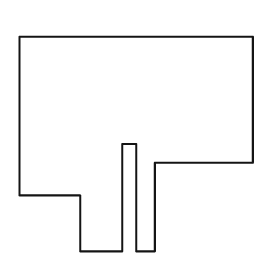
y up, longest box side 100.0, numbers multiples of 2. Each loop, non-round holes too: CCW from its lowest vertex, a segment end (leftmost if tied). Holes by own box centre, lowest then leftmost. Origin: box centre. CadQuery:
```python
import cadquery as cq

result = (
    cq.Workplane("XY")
    .moveTo(-24.0, -46.0)
    .lineTo(-6.0, -46.0)
    .lineTo(-6.0, 0.0)
    .lineTo(0.0, 0.0)
    .lineTo(0.0, -46.0)
    .lineTo(8.0, -46.0)
    .lineTo(8.0, -8.0)
    .lineTo(50.0, -8.0)
    .lineTo(50.0, 46.0)
    .lineTo(-50.0, 46.0)
    .lineTo(-50.0, -22.0)
    .lineTo(-24.0, -22.0)
    .close()
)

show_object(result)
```